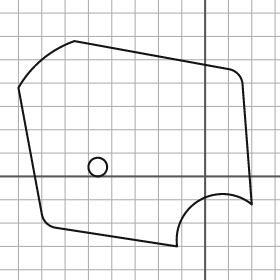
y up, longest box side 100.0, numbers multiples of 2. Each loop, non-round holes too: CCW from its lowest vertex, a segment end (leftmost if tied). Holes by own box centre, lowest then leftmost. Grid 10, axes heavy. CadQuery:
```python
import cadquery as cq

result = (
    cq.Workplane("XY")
    .moveTo(-12.0, -30.0)
    .threePointArc((-2.0, -10.0), (20.0, -12.0))
    .lineTo(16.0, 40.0)
    .threePointArc((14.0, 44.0), (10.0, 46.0))
    .lineTo(-56.0, 58.0)
    .threePointArc((-70.0, 50.0), (-80.0, 38.0))
    .lineTo(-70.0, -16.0)
    .threePointArc((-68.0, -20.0), (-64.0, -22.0))
    .close()
    .moveTo(-46.0, 4.0)
    .circle(4.0)
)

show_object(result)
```